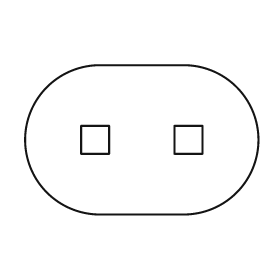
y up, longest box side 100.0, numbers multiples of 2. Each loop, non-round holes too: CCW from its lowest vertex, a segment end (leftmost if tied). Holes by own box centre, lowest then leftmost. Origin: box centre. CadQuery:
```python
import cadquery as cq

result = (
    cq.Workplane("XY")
    .moveTo(-18.0, -32.0)
    .lineTo(18.0, -32.0)
    .threePointArc((50.0, 0.0), (18.0, 32.0))
    .lineTo(-18.0, 32.0)
    .threePointArc((-50.0, 0.0), (-18.0, -32.0))
    .close()
    .moveTo(-26.0, -6.0)
    .lineTo(-14.0, -6.0)
    .lineTo(-14.0, 6.0)
    .lineTo(-26.0, 6.0)
    .close()
    .moveTo(14.0, -6.0)
    .lineTo(26.0, -6.0)
    .lineTo(26.0, 6.0)
    .lineTo(14.0, 6.0)
    .close()
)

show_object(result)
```